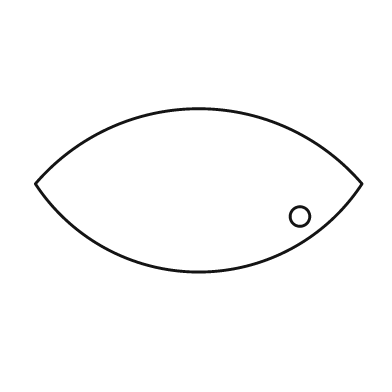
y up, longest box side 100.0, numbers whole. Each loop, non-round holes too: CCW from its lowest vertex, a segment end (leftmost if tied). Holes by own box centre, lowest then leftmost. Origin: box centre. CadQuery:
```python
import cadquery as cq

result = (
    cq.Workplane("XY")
    .moveTo(-50.0, 2.0)
    .threePointArc((0.0, -25.0), (50.0, 2.0))
    .threePointArc((0.0, 25.0), (-50.0, 2.0))
    .close()
    .moveTo(31.0, -8.0)
    .circle(3.0)
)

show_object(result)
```